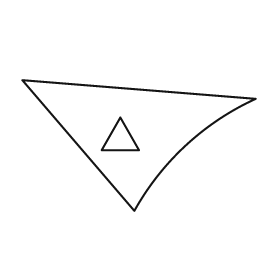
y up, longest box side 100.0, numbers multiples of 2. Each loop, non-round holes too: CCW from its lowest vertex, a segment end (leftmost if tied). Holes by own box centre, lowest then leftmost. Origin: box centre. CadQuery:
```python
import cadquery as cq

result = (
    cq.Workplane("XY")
    .moveTo(-2.0, -28.0)
    .threePointArc((20.0, 0.0), (50.0, 20.0))
    .lineTo(-50.0, 28.0)
    .close()
    .moveTo(-16.0, -2.0)
    .lineTo(0.0, -2.0)
    .lineTo(-8.0, 12.0)
    .close()
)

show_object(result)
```